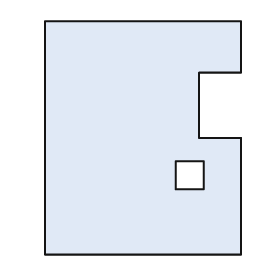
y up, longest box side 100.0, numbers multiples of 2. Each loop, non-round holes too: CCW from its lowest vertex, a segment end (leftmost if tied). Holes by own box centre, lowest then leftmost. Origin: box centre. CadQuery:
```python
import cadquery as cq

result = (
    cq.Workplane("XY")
    .moveTo(-42.0, -50.0)
    .lineTo(42.0, -50.0)
    .lineTo(42.0, 0.0)
    .lineTo(24.0, 0.0)
    .lineTo(24.0, 28.0)
    .lineTo(42.0, 28.0)
    .lineTo(42.0, 50.0)
    .lineTo(-42.0, 50.0)
    .close()
    .moveTo(14.0, -22.0)
    .lineTo(26.0, -22.0)
    .lineTo(26.0, -10.0)
    .lineTo(14.0, -10.0)
    .close()
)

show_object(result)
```